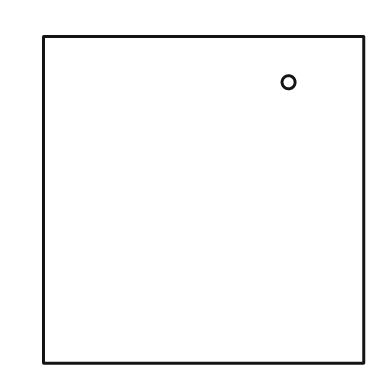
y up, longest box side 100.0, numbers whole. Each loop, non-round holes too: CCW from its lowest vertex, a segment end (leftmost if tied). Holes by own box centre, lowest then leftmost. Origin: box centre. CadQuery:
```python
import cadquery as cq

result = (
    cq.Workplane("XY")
    .moveTo(-49.0, -50.0)
    .lineTo(49.0, -50.0)
    .lineTo(49.0, 50.0)
    .lineTo(-49.0, 50.0)
    .close()
    .moveTo(26.0, 36.0)
    .circle(2.0)
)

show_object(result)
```